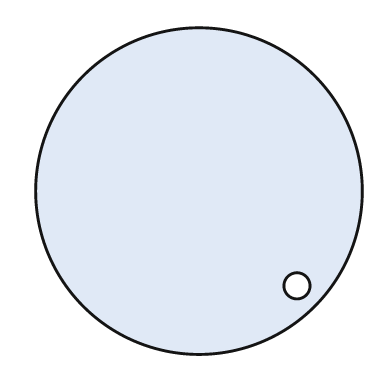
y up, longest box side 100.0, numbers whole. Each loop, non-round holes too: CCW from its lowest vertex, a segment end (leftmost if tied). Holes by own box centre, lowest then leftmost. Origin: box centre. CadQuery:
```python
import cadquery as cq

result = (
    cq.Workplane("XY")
    .moveTo(0.0, 0.0)
    .circle(50.0)
    .moveTo(30.0, -29.0)
    .circle(4.0)
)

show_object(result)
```